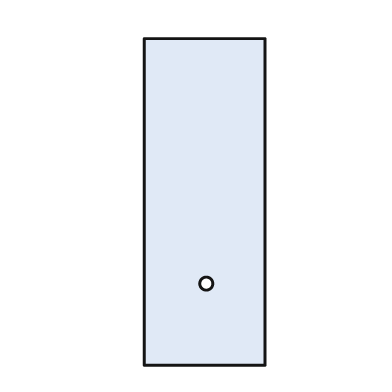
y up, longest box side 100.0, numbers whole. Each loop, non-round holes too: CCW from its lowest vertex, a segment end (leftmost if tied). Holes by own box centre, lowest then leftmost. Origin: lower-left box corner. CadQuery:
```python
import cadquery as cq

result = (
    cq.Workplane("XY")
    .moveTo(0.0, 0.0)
    .lineTo(37.0, 0.0)
    .lineTo(37.0, 100.0)
    .lineTo(0.0, 100.0)
    .close()
    .moveTo(19.0, 25.0)
    .circle(2.0)
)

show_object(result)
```